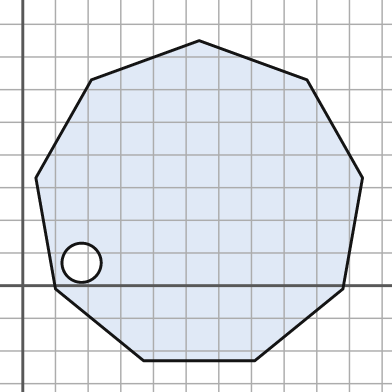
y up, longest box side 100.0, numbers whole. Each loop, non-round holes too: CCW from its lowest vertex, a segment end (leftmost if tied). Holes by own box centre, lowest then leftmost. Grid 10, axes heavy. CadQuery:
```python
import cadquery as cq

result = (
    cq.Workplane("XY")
    .moveTo(37.0, -23.0)
    .lineTo(71.0, -23.0)
    .lineTo(98.0, -1.0)
    .lineTo(104.0, 33.0)
    .lineTo(87.0, 63.0)
    .lineTo(54.0, 75.0)
    .lineTo(21.0, 63.0)
    .lineTo(4.0, 33.0)
    .lineTo(10.0, -1.0)
    .close()
    .moveTo(18.0, 7.0)
    .circle(6.0)
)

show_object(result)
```